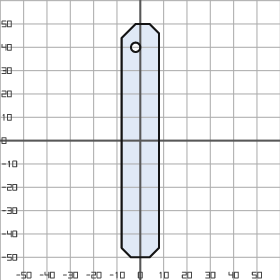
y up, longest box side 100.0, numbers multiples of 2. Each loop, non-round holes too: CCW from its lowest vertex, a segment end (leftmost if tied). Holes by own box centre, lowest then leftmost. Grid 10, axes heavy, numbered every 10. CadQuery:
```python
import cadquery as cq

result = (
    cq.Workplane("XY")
    .moveTo(-4.0, -50.0)
    .lineTo(4.0, -50.0)
    .lineTo(8.0, -46.0)
    .lineTo(8.0, 46.0)
    .lineTo(4.0, 50.0)
    .lineTo(-2.0, 50.0)
    .lineTo(-8.0, 44.0)
    .lineTo(-8.0, -46.0)
    .close()
    .moveTo(-2.0, 40.0)
    .circle(2.0)
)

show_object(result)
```